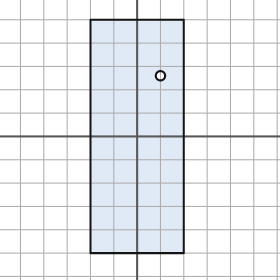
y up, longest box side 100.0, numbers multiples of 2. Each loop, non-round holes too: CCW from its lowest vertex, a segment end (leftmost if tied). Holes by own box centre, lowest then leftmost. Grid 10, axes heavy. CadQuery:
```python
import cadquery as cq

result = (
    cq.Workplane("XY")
    .moveTo(-20.0, -50.0)
    .lineTo(20.0, -50.0)
    .lineTo(20.0, 50.0)
    .lineTo(-20.0, 50.0)
    .close()
    .moveTo(10.0, 26.0)
    .circle(2.0)
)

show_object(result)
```